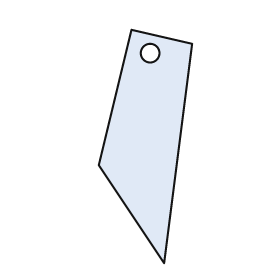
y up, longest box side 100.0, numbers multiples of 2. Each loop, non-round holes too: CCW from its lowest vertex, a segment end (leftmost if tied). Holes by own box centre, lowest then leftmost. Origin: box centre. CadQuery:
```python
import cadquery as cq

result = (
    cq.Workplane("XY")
    .moveTo(8.0, -50.0)
    .lineTo(20.0, 44.0)
    .lineTo(-6.0, 50.0)
    .lineTo(-20.0, -8.0)
    .close()
    .moveTo(2.0, 40.0)
    .circle(4.0)
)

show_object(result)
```